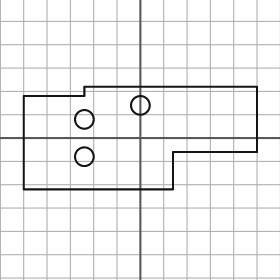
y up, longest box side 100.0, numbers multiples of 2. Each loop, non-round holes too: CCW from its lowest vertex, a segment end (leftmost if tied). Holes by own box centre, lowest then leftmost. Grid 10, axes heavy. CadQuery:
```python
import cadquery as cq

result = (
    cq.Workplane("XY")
    .moveTo(-50.0, -22.0)
    .lineTo(14.0, -22.0)
    .lineTo(14.0, -6.0)
    .lineTo(50.0, -6.0)
    .lineTo(50.0, 22.0)
    .lineTo(-24.0, 22.0)
    .lineTo(-24.0, 18.0)
    .lineTo(-50.0, 18.0)
    .close()
    .moveTo(-24.0, -8.0)
    .circle(4.0)
    .moveTo(-24.0, 8.0)
    .circle(4.0)
    .moveTo(0.0, 14.0)
    .circle(4.0)
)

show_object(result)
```